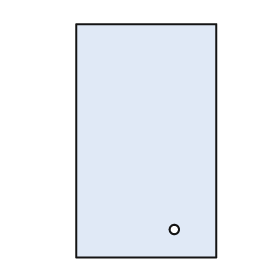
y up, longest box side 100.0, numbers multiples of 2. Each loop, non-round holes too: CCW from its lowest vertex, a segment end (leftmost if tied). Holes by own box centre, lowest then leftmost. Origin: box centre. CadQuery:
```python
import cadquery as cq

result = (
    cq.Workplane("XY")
    .moveTo(-30.0, -50.0)
    .lineTo(30.0, -50.0)
    .lineTo(30.0, 50.0)
    .lineTo(-30.0, 50.0)
    .close()
    .moveTo(12.0, -38.0)
    .circle(2.0)
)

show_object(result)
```